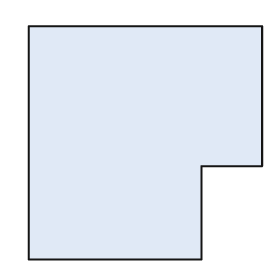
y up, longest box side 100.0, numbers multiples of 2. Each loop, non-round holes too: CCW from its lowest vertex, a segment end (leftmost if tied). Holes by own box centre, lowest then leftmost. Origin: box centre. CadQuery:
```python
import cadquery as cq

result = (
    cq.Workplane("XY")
    .moveTo(-50.0, -50.0)
    .lineTo(24.0, -50.0)
    .lineTo(24.0, -10.0)
    .lineTo(50.0, -10.0)
    .lineTo(50.0, 50.0)
    .lineTo(-50.0, 50.0)
    .close()
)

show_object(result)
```